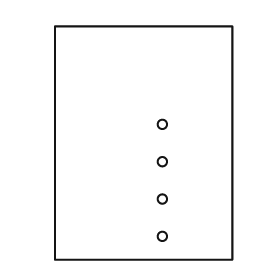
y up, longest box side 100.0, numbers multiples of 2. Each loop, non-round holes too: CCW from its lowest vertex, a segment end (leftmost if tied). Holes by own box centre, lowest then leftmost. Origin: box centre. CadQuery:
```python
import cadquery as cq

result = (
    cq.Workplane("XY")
    .moveTo(-38.0, -50.0)
    .lineTo(38.0, -50.0)
    .lineTo(38.0, 50.0)
    .lineTo(-38.0, 50.0)
    .close()
    .moveTo(8.0, -40.0)
    .circle(2.0)
    .moveTo(8.0, -24.0)
    .circle(2.0)
    .moveTo(8.0, -8.0)
    .circle(2.0)
    .moveTo(8.0, 8.0)
    .circle(2.0)
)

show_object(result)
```